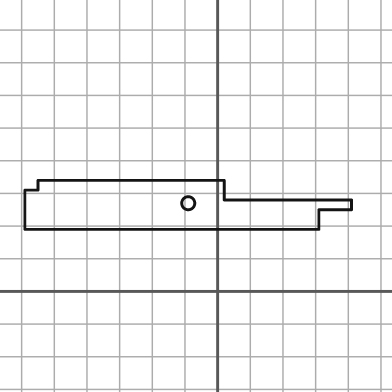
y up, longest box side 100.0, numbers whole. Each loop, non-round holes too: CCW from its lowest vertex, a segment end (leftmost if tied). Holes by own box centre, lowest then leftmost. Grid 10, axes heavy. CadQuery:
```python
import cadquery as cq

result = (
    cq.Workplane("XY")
    .moveTo(-59.0, 19.0)
    .lineTo(31.0, 19.0)
    .lineTo(31.0, 25.0)
    .lineTo(41.0, 25.0)
    .lineTo(41.0, 28.0)
    .lineTo(2.0, 28.0)
    .lineTo(2.0, 34.0)
    .lineTo(-55.0, 34.0)
    .lineTo(-55.0, 31.0)
    .lineTo(-59.0, 31.0)
    .close()
    .moveTo(-9.0, 27.0)
    .circle(2.0)
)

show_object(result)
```